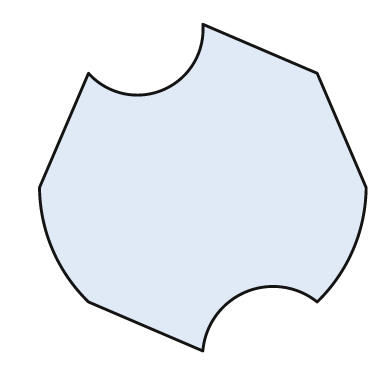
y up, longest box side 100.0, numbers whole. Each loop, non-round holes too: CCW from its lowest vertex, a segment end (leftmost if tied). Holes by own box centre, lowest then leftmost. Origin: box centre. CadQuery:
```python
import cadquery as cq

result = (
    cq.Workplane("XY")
    .moveTo(0.0, -50.0)
    .threePointArc((13.0, -32.0), (35.0, -35.0))
    .threePointArc((46.0, -19.0), (50.0, 0.0))
    .lineTo(35.0, 35.0)
    .lineTo(0.0, 50.0)
    .threePointArc((-12.0, 30.0), (-35.0, 35.0))
    .lineTo(-50.0, 0.0)
    .threePointArc((-46.0, -19.0), (-35.0, -35.0))
    .close()
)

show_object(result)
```